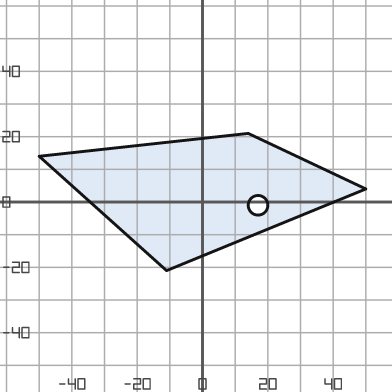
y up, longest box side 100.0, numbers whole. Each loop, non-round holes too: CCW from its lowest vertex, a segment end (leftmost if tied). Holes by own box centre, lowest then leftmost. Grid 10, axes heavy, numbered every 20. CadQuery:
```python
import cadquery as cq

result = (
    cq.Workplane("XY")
    .moveTo(-11.0, -21.0)
    .lineTo(50.0, 4.0)
    .lineTo(14.0, 21.0)
    .lineTo(-50.0, 14.0)
    .close()
    .moveTo(17.0, -1.0)
    .circle(3.0)
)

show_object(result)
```